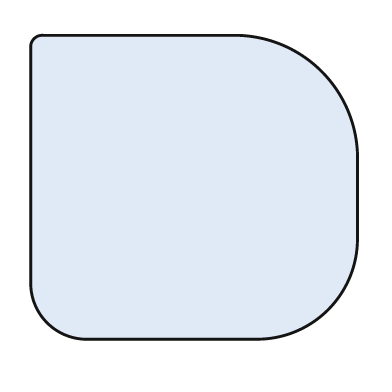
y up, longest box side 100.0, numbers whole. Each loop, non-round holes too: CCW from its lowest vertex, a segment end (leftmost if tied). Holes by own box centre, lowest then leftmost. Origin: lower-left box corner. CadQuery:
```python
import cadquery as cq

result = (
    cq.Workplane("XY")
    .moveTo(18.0, 0.0)
    .lineTo(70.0, 0.0)
    .threePointArc((91.0, 9.0), (100.0, 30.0))
    .lineTo(100.0, 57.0)
    .threePointArc((89.0, 82.0), (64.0, 93.0))
    .lineTo(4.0, 93.0)
    .threePointArc((1.0, 92.0), (0.0, 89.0))
    .lineTo(0.0, 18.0)
    .threePointArc((5.0, 5.0), (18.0, 0.0))
    .close()
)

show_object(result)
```